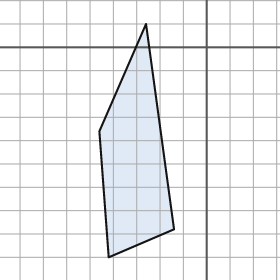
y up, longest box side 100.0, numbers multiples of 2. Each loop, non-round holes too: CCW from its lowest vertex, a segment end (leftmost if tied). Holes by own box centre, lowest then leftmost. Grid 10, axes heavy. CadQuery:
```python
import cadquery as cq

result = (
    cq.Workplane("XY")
    .moveTo(-42.0, -90.0)
    .lineTo(-14.0, -78.0)
    .lineTo(-26.0, 10.0)
    .lineTo(-46.0, -36.0)
    .close()
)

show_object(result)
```